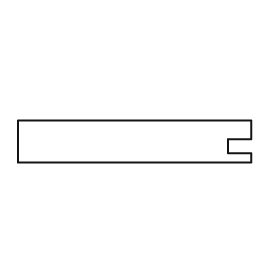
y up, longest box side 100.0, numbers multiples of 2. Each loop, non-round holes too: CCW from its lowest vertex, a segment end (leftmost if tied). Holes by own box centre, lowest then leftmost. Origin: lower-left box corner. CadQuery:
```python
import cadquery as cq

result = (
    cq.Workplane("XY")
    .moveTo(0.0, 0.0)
    .lineTo(100.0, 0.0)
    .lineTo(100.0, 4.0)
    .lineTo(90.0, 4.0)
    .lineTo(90.0, 10.0)
    .lineTo(100.0, 10.0)
    .lineTo(100.0, 18.0)
    .lineTo(0.0, 18.0)
    .close()
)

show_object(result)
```